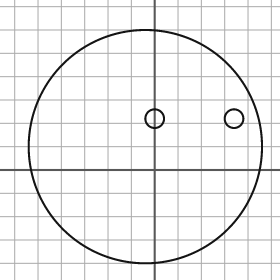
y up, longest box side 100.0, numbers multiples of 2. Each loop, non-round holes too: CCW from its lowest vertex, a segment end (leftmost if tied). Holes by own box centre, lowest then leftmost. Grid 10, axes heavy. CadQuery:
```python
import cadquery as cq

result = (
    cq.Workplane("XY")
    .moveTo(-4.0, 10.0)
    .circle(50.0)
    .moveTo(0.0, 22.0)
    .circle(4.0)
    .moveTo(34.0, 22.0)
    .circle(4.0)
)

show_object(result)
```